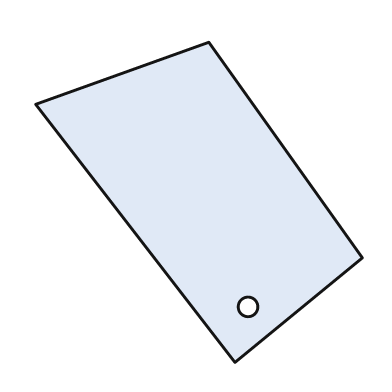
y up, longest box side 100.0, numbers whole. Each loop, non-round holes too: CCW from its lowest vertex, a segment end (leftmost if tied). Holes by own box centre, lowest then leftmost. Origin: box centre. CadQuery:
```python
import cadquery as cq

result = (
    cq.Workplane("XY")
    .moveTo(11.0, -49.0)
    .lineTo(50.0, -17.0)
    .lineTo(3.0, 49.0)
    .lineTo(-50.0, 30.0)
    .close()
    .moveTo(15.0, -32.0)
    .circle(3.0)
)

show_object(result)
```